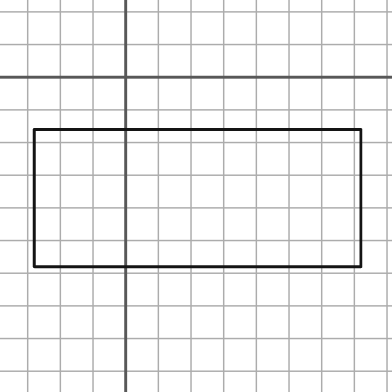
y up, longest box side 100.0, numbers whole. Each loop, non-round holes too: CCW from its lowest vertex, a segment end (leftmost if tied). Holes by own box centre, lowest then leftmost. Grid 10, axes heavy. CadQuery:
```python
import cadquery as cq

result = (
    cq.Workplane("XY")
    .moveTo(-28.0, -58.0)
    .lineTo(72.0, -58.0)
    .lineTo(72.0, -16.0)
    .lineTo(-28.0, -16.0)
    .close()
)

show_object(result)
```